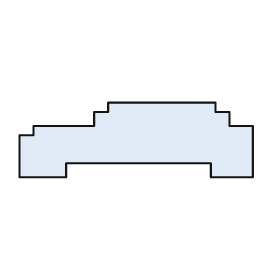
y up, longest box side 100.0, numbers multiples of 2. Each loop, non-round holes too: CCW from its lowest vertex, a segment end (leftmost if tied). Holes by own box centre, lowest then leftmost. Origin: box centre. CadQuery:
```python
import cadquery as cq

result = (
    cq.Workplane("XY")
    .moveTo(-50.0, -16.0)
    .lineTo(-30.0, -16.0)
    .lineTo(-30.0, -10.0)
    .lineTo(32.0, -10.0)
    .lineTo(32.0, -16.0)
    .lineTo(50.0, -16.0)
    .lineTo(50.0, 6.0)
    .lineTo(40.0, 6.0)
    .lineTo(40.0, 12.0)
    .lineTo(34.0, 12.0)
    .lineTo(34.0, 16.0)
    .lineTo(-12.0, 16.0)
    .lineTo(-12.0, 12.0)
    .lineTo(-18.0, 12.0)
    .lineTo(-18.0, 6.0)
    .lineTo(-44.0, 6.0)
    .lineTo(-44.0, 2.0)
    .lineTo(-50.0, 2.0)
    .close()
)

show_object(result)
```